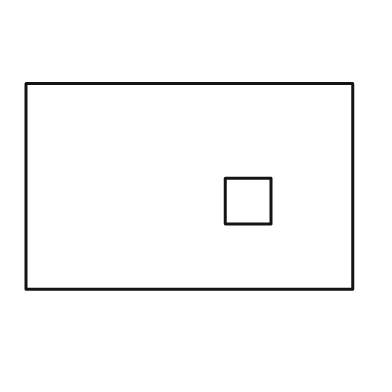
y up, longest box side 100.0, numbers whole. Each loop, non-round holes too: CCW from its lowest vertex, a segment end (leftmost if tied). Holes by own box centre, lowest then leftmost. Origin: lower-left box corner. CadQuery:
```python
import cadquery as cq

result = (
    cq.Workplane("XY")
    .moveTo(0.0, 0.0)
    .lineTo(100.0, 0.0)
    .lineTo(100.0, 63.0)
    .lineTo(0.0, 63.0)
    .close()
    .moveTo(61.0, 20.0)
    .lineTo(75.0, 20.0)
    .lineTo(75.0, 34.0)
    .lineTo(61.0, 34.0)
    .close()
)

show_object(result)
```